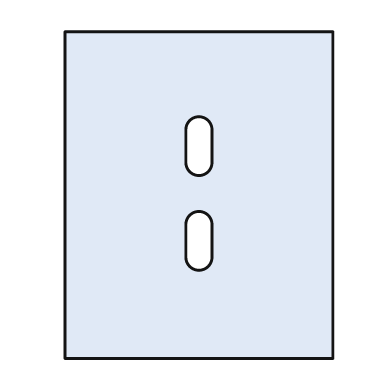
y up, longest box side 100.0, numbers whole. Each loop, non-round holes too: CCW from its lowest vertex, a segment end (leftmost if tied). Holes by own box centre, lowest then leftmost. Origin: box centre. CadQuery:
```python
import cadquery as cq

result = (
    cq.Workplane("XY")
    .moveTo(-41.0, -50.0)
    .lineTo(41.0, -50.0)
    .lineTo(41.0, 50.0)
    .lineTo(-41.0, 50.0)
    .close()
    .moveTo(-4.0, -19.0)
    .threePointArc((0.0, -23.0), (4.0, -19.0))
    .lineTo(4.0, -9.0)
    .threePointArc((0.0, -5.0), (-4.0, -9.0))
    .close()
    .moveTo(-4.0, 10.0)
    .threePointArc((0.0, 6.0), (4.0, 10.0))
    .lineTo(4.0, 20.0)
    .threePointArc((0.0, 24.0), (-4.0, 20.0))
    .close()
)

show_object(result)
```